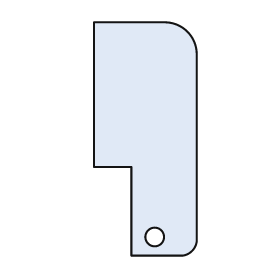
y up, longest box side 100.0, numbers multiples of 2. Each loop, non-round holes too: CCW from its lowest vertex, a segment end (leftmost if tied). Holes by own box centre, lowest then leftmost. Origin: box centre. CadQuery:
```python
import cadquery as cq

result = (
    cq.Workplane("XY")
    .moveTo(-6.0, -50.0)
    .lineTo(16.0, -50.0)
    .threePointArc((20.0, -48.0), (22.0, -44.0))
    .lineTo(22.0, 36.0)
    .threePointArc((18.0, 46.0), (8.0, 50.0))
    .lineTo(-22.0, 50.0)
    .lineTo(-22.0, -12.0)
    .lineTo(-6.0, -12.0)
    .close()
    .moveTo(4.0, -42.0)
    .circle(4.0)
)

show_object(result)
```